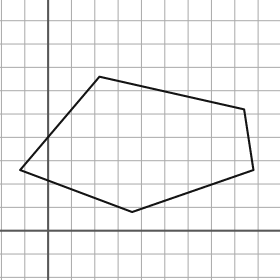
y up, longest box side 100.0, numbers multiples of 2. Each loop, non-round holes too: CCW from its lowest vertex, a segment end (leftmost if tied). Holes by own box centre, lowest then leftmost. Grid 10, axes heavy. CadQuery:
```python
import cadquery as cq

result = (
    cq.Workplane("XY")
    .moveTo(36.0, 8.0)
    .lineTo(88.0, 26.0)
    .lineTo(84.0, 52.0)
    .lineTo(22.0, 66.0)
    .lineTo(-12.0, 26.0)
    .close()
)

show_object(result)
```